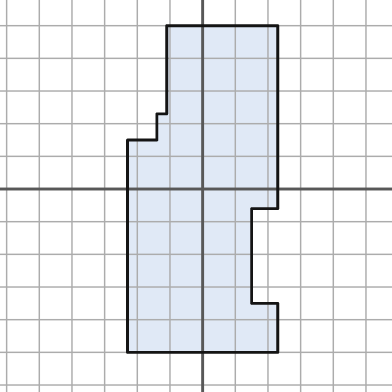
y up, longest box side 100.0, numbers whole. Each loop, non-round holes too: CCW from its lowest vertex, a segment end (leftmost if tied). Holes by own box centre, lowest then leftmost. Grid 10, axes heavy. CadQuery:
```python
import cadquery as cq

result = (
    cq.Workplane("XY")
    .moveTo(-23.0, -50.0)
    .lineTo(23.0, -50.0)
    .lineTo(23.0, -35.0)
    .lineTo(15.0, -35.0)
    .lineTo(15.0, -6.0)
    .lineTo(23.0, -6.0)
    .lineTo(23.0, 50.0)
    .lineTo(-11.0, 50.0)
    .lineTo(-11.0, 23.0)
    .lineTo(-14.0, 23.0)
    .lineTo(-14.0, 15.0)
    .lineTo(-23.0, 15.0)
    .close()
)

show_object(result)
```